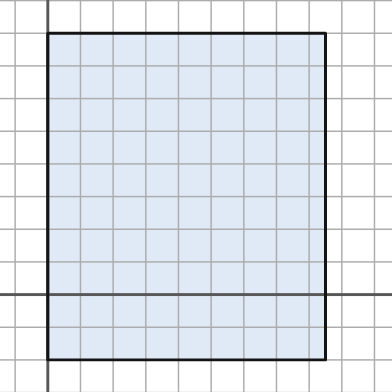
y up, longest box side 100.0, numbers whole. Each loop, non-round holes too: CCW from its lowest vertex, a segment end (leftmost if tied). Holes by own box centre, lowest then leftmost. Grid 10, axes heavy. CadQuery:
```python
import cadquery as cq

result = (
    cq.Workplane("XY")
    .moveTo(0.0, -20.0)
    .lineTo(85.0, -20.0)
    .lineTo(85.0, 80.0)
    .lineTo(0.0, 80.0)
    .close()
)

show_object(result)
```